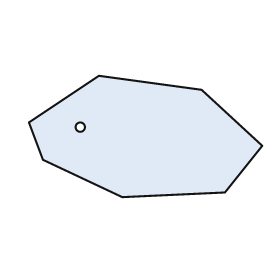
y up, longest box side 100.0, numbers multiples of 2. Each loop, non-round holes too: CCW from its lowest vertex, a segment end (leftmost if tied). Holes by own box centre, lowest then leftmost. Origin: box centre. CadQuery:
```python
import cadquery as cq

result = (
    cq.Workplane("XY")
    .moveTo(-10.0, -26.0)
    .lineTo(34.0, -24.0)
    .lineTo(50.0, -4.0)
    .lineTo(24.0, 20.0)
    .lineTo(-20.0, 26.0)
    .lineTo(-50.0, 6.0)
    .lineTo(-44.0, -10.0)
    .close()
    .moveTo(-28.0, 4.0)
    .circle(2.0)
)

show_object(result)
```